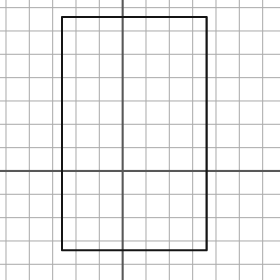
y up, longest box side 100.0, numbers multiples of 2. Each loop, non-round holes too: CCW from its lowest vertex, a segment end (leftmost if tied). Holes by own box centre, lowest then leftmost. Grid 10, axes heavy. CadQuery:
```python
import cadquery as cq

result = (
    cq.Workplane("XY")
    .moveTo(-26.0, -34.0)
    .lineTo(36.0, -34.0)
    .lineTo(36.0, 66.0)
    .lineTo(-26.0, 66.0)
    .close()
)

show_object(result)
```